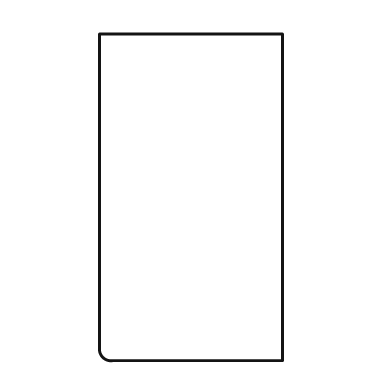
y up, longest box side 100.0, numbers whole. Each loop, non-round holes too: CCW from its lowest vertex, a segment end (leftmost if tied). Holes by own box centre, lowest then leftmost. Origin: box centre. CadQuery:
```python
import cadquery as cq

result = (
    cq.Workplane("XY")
    .moveTo(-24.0, -50.0)
    .lineTo(28.0, -50.0)
    .lineTo(28.0, 50.0)
    .lineTo(-28.0, 50.0)
    .lineTo(-28.0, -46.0)
    .threePointArc((-27.0, -49.0), (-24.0, -50.0))
    .close()
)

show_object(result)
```